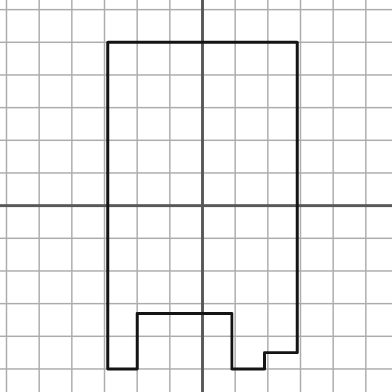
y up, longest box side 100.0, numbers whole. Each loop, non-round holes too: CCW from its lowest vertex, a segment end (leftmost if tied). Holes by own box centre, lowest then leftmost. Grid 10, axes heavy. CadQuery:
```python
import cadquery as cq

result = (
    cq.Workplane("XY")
    .moveTo(-29.0, -50.0)
    .lineTo(-20.0, -50.0)
    .lineTo(-20.0, -33.0)
    .lineTo(9.0, -33.0)
    .lineTo(9.0, -50.0)
    .lineTo(19.0, -50.0)
    .lineTo(19.0, -45.0)
    .lineTo(29.0, -45.0)
    .lineTo(29.0, 50.0)
    .lineTo(-29.0, 50.0)
    .close()
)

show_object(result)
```